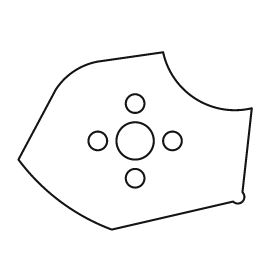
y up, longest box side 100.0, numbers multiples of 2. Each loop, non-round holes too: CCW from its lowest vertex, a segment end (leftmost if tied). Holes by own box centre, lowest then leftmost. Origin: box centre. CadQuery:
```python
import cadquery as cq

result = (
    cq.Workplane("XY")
    .moveTo(-10.0, -38.0)
    .lineTo(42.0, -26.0)
    .threePointArc((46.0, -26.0), (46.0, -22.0))
    .lineTo(50.0, 14.0)
    .threePointArc((26.0, 18.0), (12.0, 38.0))
    .lineTo(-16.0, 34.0)
    .threePointArc((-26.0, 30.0), (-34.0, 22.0))
    .lineTo(-50.0, -8.0)
    .threePointArc((-32.0, -26.0), (-10.0, -38.0))
    .close()
    .moveTo(0.0, -16.0)
    .circle(4.0)
    .moveTo(-16.0, 0.0)
    .circle(4.0)
    .moveTo(0.0, 0.0)
    .circle(8.0)
    .moveTo(16.0, 0.0)
    .circle(4.0)
    .moveTo(0.0, 16.0)
    .circle(4.0)
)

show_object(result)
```